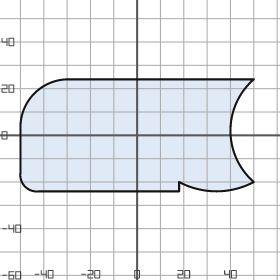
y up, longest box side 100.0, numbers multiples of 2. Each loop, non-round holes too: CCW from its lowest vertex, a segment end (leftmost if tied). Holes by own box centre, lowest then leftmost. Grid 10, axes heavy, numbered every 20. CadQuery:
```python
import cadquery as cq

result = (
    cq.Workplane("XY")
    .moveTo(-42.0, -24.0)
    .lineTo(18.0, -24.0)
    .lineTo(18.0, -20.0)
    .threePointArc((34.0, -24.0), (50.0, -20.0))
    .threePointArc((40.0, 2.0), (50.0, 24.0))
    .lineTo(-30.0, 24.0)
    .threePointArc((-44.0, 18.0), (-50.0, 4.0))
    .lineTo(-50.0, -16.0)
    .threePointArc((-48.0, -22.0), (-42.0, -24.0))
    .close()
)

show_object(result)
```